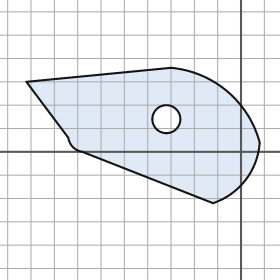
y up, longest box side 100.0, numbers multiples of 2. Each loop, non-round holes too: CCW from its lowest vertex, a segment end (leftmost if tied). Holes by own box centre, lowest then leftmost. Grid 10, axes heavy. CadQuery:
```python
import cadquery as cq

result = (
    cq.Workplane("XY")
    .moveTo(-12.0, -22.0)
    .threePointArc((2.0, -12.0), (8.0, 4.0))
    .threePointArc((-6.0, 26.0), (-30.0, 36.0))
    .lineTo(-92.0, 30.0)
    .lineTo(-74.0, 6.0)
    .threePointArc((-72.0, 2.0), (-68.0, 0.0))
    .close()
    .moveTo(-32.0, 14.0)
    .circle(6.0)
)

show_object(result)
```